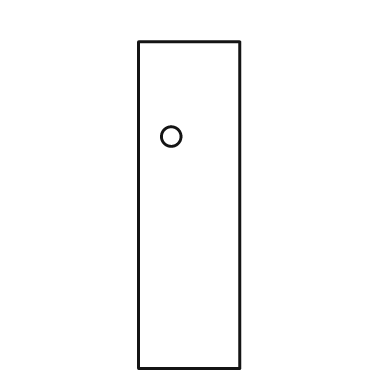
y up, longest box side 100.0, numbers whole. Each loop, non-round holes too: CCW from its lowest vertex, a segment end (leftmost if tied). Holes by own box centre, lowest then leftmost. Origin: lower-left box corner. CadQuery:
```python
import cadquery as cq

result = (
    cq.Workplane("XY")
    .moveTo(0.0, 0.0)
    .lineTo(31.0, 0.0)
    .lineTo(31.0, 100.0)
    .lineTo(0.0, 100.0)
    .close()
    .moveTo(10.0, 71.0)
    .circle(3.0)
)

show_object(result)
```